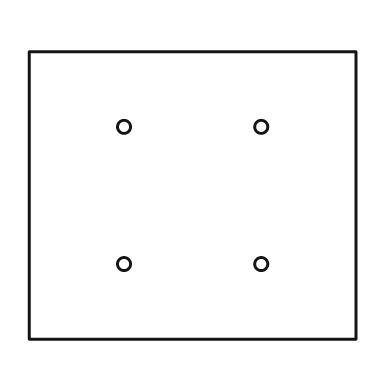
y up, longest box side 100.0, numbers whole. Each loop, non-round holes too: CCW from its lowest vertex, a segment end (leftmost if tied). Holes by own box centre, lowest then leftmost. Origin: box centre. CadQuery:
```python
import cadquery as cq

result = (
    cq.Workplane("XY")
    .moveTo(-50.0, -44.0)
    .lineTo(50.0, -44.0)
    .lineTo(50.0, 44.0)
    .lineTo(-50.0, 44.0)
    .close()
    .moveTo(-21.0, -21.0)
    .circle(2.0)
    .moveTo(21.0, -21.0)
    .circle(2.0)
    .moveTo(-21.0, 21.0)
    .circle(2.0)
    .moveTo(21.0, 21.0)
    .circle(2.0)
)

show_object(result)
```